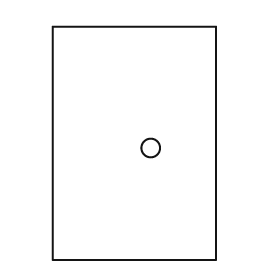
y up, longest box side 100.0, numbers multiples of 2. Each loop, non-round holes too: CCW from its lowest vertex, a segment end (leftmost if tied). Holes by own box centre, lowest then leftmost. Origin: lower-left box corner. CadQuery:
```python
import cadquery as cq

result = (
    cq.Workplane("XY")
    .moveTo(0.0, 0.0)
    .lineTo(70.0, 0.0)
    .lineTo(70.0, 100.0)
    .lineTo(0.0, 100.0)
    .close()
    .moveTo(42.0, 48.0)
    .circle(4.0)
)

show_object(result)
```